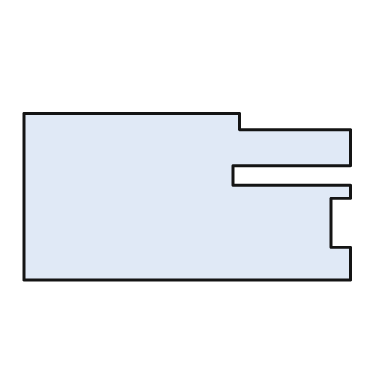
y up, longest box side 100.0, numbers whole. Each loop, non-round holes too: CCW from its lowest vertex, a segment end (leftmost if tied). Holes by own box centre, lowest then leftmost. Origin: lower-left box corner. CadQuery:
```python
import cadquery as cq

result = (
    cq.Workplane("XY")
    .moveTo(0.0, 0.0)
    .lineTo(100.0, 0.0)
    .lineTo(100.0, 10.0)
    .lineTo(94.0, 10.0)
    .lineTo(94.0, 25.0)
    .lineTo(100.0, 25.0)
    .lineTo(100.0, 29.0)
    .lineTo(64.0, 29.0)
    .lineTo(64.0, 35.0)
    .lineTo(100.0, 35.0)
    .lineTo(100.0, 46.0)
    .lineTo(66.0, 46.0)
    .lineTo(66.0, 51.0)
    .lineTo(0.0, 51.0)
    .close()
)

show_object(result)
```